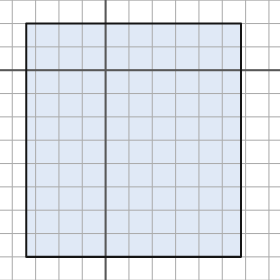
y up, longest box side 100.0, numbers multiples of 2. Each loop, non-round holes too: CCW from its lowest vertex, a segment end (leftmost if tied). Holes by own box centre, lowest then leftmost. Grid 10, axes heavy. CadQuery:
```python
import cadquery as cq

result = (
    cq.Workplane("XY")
    .moveTo(-34.0, -80.0)
    .lineTo(58.0, -80.0)
    .lineTo(58.0, 20.0)
    .lineTo(-34.0, 20.0)
    .close()
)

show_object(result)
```